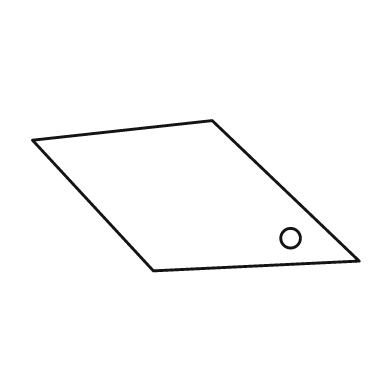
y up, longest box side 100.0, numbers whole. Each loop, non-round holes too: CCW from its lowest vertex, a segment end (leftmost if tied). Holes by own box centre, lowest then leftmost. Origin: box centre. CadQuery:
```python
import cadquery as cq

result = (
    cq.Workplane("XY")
    .moveTo(-13.0, -23.0)
    .lineTo(50.0, -20.0)
    .lineTo(5.0, 23.0)
    .lineTo(-50.0, 17.0)
    .close()
    .moveTo(29.0, -13.0)
    .circle(3.0)
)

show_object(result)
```